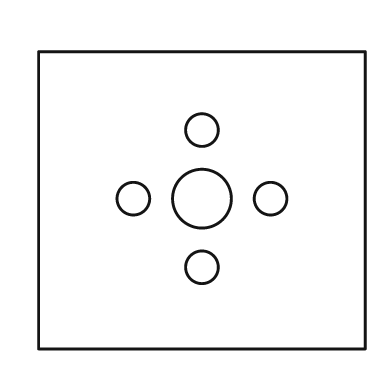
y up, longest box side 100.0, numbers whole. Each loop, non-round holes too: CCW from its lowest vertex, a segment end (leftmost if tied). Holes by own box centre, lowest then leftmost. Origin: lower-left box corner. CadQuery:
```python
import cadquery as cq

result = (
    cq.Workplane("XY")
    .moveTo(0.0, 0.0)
    .lineTo(100.0, 0.0)
    .lineTo(100.0, 91.0)
    .lineTo(0.0, 91.0)
    .close()
    .moveTo(50.0, 25.0)
    .circle(5.0)
    .moveTo(29.0, 46.0)
    .circle(5.0)
    .moveTo(50.0, 46.0)
    .circle(9.0)
    .moveTo(71.0, 46.0)
    .circle(5.0)
    .moveTo(50.0, 67.0)
    .circle(5.0)
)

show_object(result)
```